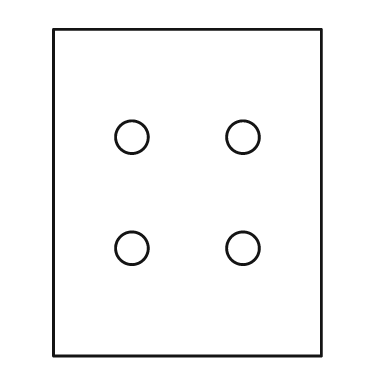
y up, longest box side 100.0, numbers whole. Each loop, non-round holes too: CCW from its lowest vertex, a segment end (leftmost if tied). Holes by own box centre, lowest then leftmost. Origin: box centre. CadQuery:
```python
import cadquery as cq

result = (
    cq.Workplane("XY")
    .moveTo(-41.0, -50.0)
    .lineTo(41.0, -50.0)
    .lineTo(41.0, 50.0)
    .lineTo(-41.0, 50.0)
    .close()
    .moveTo(-17.0, -17.0)
    .circle(5.0)
    .moveTo(17.0, -17.0)
    .circle(5.0)
    .moveTo(-17.0, 17.0)
    .circle(5.0)
    .moveTo(17.0, 17.0)
    .circle(5.0)
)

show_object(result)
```